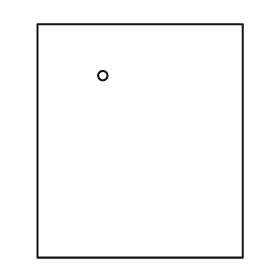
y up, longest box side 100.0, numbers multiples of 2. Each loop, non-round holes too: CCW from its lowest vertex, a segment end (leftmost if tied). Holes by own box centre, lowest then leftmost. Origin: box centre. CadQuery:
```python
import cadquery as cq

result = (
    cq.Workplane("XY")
    .moveTo(-44.0, -50.0)
    .lineTo(44.0, -50.0)
    .lineTo(44.0, 50.0)
    .lineTo(-44.0, 50.0)
    .close()
    .moveTo(-16.0, 28.0)
    .circle(2.0)
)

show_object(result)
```